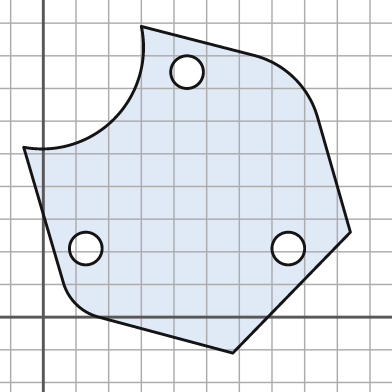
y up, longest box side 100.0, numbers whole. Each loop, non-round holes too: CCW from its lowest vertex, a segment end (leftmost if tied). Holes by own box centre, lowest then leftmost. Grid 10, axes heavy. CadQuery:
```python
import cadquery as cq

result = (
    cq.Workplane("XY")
    .moveTo(58.0, -11.0)
    .lineTo(94.0, 26.0)
    .lineTo(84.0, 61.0)
    .threePointArc((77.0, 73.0), (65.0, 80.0))
    .lineTo(30.0, 89.0)
    .threePointArc((22.0, 61.0), (-6.0, 52.0))
    .lineTo(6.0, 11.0)
    .threePointArc((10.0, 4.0), (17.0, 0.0))
    .close()
    .moveTo(13.0, 21.0)
    .circle(5.0)
    .moveTo(75.0, 21.0)
    .circle(5.0)
    .moveTo(44.0, 75.0)
    .circle(5.0)
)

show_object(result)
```